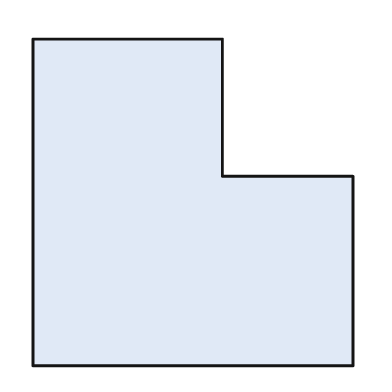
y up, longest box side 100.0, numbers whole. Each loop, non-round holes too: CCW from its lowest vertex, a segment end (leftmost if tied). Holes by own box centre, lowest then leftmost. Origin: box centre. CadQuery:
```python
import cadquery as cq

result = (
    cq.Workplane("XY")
    .moveTo(-49.0, -50.0)
    .lineTo(49.0, -50.0)
    .lineTo(49.0, 8.0)
    .lineTo(9.0, 8.0)
    .lineTo(9.0, 50.0)
    .lineTo(-49.0, 50.0)
    .close()
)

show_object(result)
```